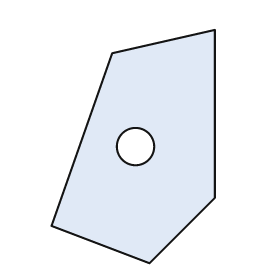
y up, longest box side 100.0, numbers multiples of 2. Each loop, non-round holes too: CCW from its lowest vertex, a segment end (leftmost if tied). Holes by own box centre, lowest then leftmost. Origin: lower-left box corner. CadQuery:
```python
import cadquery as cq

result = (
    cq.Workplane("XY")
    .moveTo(42.0, 0.0)
    .lineTo(70.0, 28.0)
    .lineTo(70.0, 100.0)
    .lineTo(26.0, 90.0)
    .lineTo(0.0, 16.0)
    .close()
    .moveTo(36.0, 50.0)
    .circle(8.0)
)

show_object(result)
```